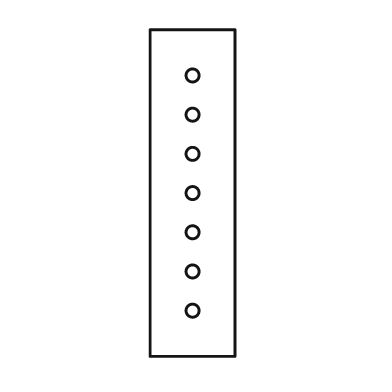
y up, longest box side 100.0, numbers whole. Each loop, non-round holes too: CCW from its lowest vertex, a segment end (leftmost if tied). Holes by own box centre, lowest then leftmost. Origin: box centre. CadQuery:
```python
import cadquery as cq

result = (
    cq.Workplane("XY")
    .moveTo(-13.0, -50.0)
    .lineTo(13.0, -50.0)
    .lineTo(13.0, 50.0)
    .lineTo(-13.0, 50.0)
    .close()
    .moveTo(0.0, -36.0)
    .circle(2.0)
    .moveTo(0.0, -24.0)
    .circle(2.0)
    .moveTo(0.0, -12.0)
    .circle(2.0)
    .moveTo(0.0, 0.0)
    .circle(2.0)
    .moveTo(0.0, 12.0)
    .circle(2.0)
    .moveTo(0.0, 24.0)
    .circle(2.0)
    .moveTo(0.0, 36.0)
    .circle(2.0)
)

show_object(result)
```